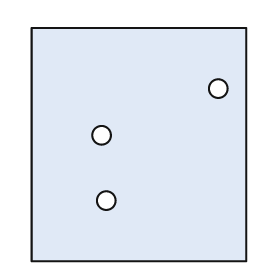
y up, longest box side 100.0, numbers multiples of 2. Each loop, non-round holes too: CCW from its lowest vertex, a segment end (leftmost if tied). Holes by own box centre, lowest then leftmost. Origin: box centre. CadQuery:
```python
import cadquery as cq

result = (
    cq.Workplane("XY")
    .moveTo(-46.0, -50.0)
    .lineTo(46.0, -50.0)
    .lineTo(46.0, 50.0)
    .lineTo(-46.0, 50.0)
    .close()
    .moveTo(-14.0, -24.0)
    .circle(4.0)
    .moveTo(-16.0, 4.0)
    .circle(4.0)
    .moveTo(34.0, 24.0)
    .circle(4.0)
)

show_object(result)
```